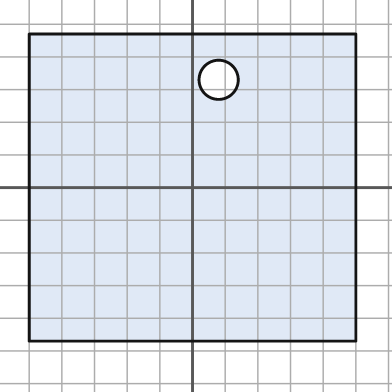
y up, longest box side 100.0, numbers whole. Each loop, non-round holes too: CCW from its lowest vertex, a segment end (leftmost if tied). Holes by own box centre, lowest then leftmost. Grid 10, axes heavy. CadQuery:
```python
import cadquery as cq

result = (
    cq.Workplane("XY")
    .moveTo(-50.0, -47.0)
    .lineTo(50.0, -47.0)
    .lineTo(50.0, 47.0)
    .lineTo(-50.0, 47.0)
    .close()
    .moveTo(8.0, 33.0)
    .circle(6.0)
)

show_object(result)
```